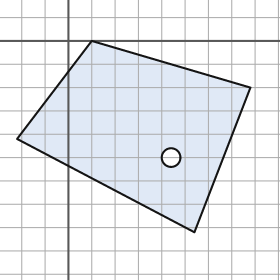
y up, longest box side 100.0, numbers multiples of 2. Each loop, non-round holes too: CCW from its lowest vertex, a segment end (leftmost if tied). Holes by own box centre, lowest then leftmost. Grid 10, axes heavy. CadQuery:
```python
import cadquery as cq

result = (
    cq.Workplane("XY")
    .moveTo(54.0, -82.0)
    .lineTo(78.0, -20.0)
    .lineTo(10.0, 0.0)
    .lineTo(-22.0, -42.0)
    .close()
    .moveTo(44.0, -50.0)
    .circle(4.0)
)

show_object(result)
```